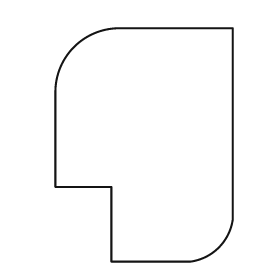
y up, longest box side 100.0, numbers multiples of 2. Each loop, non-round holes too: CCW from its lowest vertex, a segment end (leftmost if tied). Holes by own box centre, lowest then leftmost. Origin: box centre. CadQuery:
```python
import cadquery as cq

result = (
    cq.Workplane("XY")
    .moveTo(-14.0, -50.0)
    .lineTo(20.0, -50.0)
    .threePointArc((32.0, -44.0), (38.0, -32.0))
    .lineTo(38.0, 50.0)
    .lineTo(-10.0, 50.0)
    .threePointArc((-30.0, 42.0), (-38.0, 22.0))
    .lineTo(-38.0, -18.0)
    .lineTo(-14.0, -18.0)
    .close()
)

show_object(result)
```